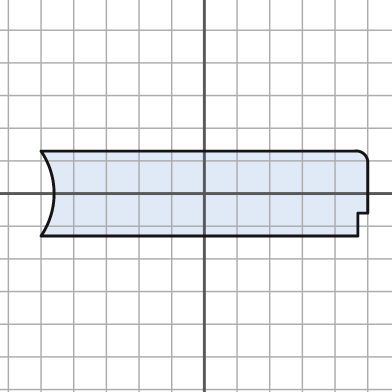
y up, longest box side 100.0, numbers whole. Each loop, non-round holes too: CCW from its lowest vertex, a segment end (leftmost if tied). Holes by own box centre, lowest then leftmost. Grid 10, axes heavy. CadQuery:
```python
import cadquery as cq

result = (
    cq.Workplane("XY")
    .moveTo(-50.0, -13.0)
    .lineTo(47.0, -13.0)
    .lineTo(47.0, -6.0)
    .lineTo(50.0, -6.0)
    .lineTo(50.0, 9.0)
    .threePointArc((49.0, 12.0), (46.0, 13.0))
    .lineTo(-50.0, 13.0)
    .threePointArc((-46.0, 0.0), (-50.0, -13.0))
    .close()
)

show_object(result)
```